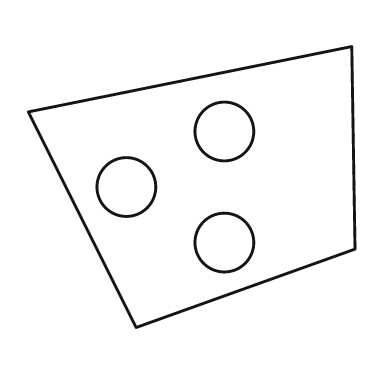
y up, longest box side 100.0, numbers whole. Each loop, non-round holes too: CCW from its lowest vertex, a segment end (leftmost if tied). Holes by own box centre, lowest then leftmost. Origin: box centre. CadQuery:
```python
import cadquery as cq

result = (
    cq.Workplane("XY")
    .moveTo(-17.0, -43.0)
    .lineTo(50.0, -19.0)
    .lineTo(49.0, 43.0)
    .lineTo(-50.0, 23.0)
    .close()
    .moveTo(10.0, -17.0)
    .circle(9.0)
    .moveTo(-20.0, 0.0)
    .circle(9.0)
    .moveTo(10.0, 17.0)
    .circle(9.0)
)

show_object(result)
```